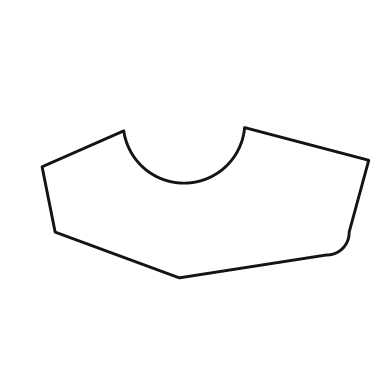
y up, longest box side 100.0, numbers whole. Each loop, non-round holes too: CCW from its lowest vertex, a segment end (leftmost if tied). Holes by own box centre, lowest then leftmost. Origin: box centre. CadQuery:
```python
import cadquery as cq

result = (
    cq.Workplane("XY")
    .moveTo(-8.0, -23.0)
    .lineTo(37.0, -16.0)
    .threePointArc((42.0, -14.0), (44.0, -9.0))
    .lineTo(50.0, 13.0)
    .lineTo(12.0, 23.0)
    .threePointArc((-6.0, 6.0), (-25.0, 22.0))
    .lineTo(-50.0, 11.0)
    .lineTo(-46.0, -9.0)
    .close()
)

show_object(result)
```